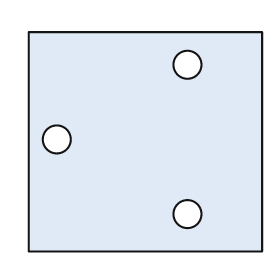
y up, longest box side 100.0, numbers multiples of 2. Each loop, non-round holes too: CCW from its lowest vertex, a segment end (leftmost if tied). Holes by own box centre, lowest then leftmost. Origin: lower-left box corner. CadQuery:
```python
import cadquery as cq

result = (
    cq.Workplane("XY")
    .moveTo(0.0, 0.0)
    .lineTo(100.0, 0.0)
    .lineTo(100.0, 94.0)
    .lineTo(0.0, 94.0)
    .close()
    .moveTo(68.0, 16.0)
    .circle(6.0)
    .moveTo(12.0, 48.0)
    .circle(6.0)
    .moveTo(68.0, 80.0)
    .circle(6.0)
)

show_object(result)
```